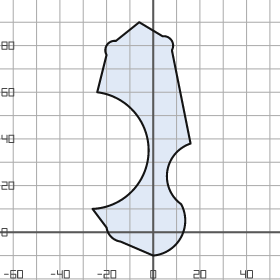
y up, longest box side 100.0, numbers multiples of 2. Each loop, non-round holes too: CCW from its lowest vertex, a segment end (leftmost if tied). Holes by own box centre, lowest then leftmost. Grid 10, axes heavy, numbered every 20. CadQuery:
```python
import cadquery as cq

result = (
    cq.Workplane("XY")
    .moveTo(0.0, -10.0)
    .threePointArc((12.0, -2.0), (12.0, 12.0))
    .threePointArc((6.0, 26.0), (16.0, 38.0))
    .lineTo(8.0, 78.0)
    .threePointArc((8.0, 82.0), (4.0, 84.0))
    .lineTo(-6.0, 90.0)
    .lineTo(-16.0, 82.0)
    .threePointArc((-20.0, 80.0), (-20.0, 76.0))
    .lineTo(-24.0, 60.0)
    .threePointArc((-2.0, 34.0), (-26.0, 10.0))
    .lineTo(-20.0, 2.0)
    .threePointArc((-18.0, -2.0), (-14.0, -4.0))
    .close()
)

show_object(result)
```